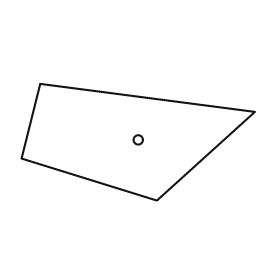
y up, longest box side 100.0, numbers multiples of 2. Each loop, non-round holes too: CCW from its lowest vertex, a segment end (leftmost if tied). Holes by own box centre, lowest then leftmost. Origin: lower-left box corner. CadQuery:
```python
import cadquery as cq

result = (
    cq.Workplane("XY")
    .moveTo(58.0, 0.0)
    .lineTo(100.0, 38.0)
    .lineTo(8.0, 50.0)
    .lineTo(0.0, 18.0)
    .close()
    .moveTo(50.0, 26.0)
    .circle(2.0)
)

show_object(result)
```